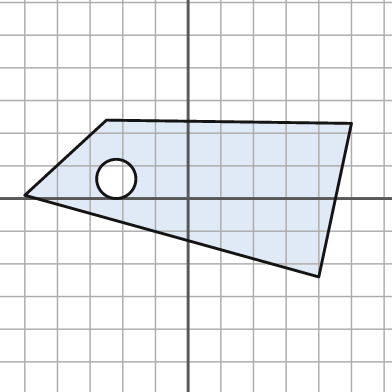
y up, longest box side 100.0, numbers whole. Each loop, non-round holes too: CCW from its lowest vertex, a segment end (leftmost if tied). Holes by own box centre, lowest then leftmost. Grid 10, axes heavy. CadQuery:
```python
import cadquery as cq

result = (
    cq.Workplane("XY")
    .moveTo(40.0, -24.0)
    .lineTo(50.0, 23.0)
    .lineTo(-25.0, 24.0)
    .lineTo(-50.0, 1.0)
    .close()
    .moveTo(-22.0, 6.0)
    .circle(6.0)
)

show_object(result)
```